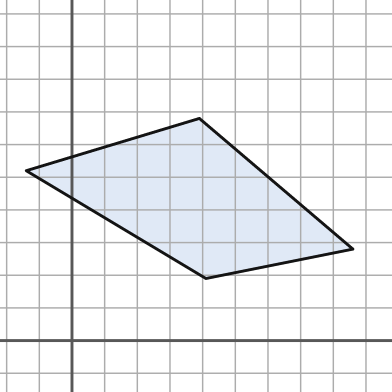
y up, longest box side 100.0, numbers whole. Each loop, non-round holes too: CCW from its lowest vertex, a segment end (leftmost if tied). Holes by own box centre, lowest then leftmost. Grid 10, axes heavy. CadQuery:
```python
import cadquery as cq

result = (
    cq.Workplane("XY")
    .moveTo(41.0, 19.0)
    .lineTo(86.0, 28.0)
    .lineTo(39.0, 68.0)
    .lineTo(-14.0, 52.0)
    .close()
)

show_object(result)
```